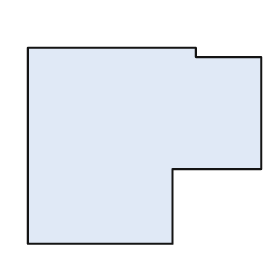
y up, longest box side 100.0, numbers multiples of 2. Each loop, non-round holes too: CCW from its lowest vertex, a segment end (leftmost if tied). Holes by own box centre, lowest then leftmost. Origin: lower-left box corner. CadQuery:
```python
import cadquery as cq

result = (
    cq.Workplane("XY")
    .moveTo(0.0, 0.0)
    .lineTo(62.0, 0.0)
    .lineTo(62.0, 32.0)
    .lineTo(100.0, 32.0)
    .lineTo(100.0, 80.0)
    .lineTo(72.0, 80.0)
    .lineTo(72.0, 84.0)
    .lineTo(0.0, 84.0)
    .close()
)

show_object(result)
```